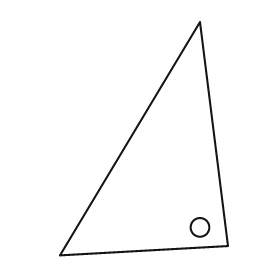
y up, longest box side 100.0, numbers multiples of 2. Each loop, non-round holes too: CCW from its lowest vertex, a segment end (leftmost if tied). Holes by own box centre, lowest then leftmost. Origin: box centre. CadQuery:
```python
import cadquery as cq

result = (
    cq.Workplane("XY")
    .moveTo(-36.0, -50.0)
    .lineTo(36.0, -46.0)
    .lineTo(24.0, 50.0)
    .close()
    .moveTo(24.0, -38.0)
    .circle(4.0)
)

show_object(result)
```